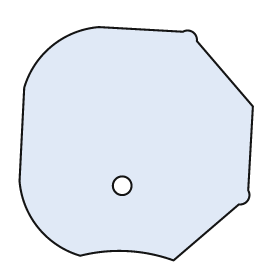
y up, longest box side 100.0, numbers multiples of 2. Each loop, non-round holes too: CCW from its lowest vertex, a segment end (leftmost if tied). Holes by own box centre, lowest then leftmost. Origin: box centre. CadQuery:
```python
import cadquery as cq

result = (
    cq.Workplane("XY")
    .moveTo(16.0, -50.0)
    .lineTo(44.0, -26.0)
    .threePointArc((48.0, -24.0), (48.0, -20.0))
    .lineTo(50.0, 16.0)
    .lineTo(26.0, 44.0)
    .threePointArc((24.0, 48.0), (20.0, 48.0))
    .lineTo(-16.0, 50.0)
    .threePointArc((-36.0, 42.0), (-48.0, 24.0))
    .lineTo(-50.0, -16.0)
    .threePointArc((-42.0, -36.0), (-24.0, -48.0))
    .threePointArc((-4.0, -46.0), (16.0, -50.0))
    .close()
    .moveTo(-6.0, -18.0)
    .circle(4.0)
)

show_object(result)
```